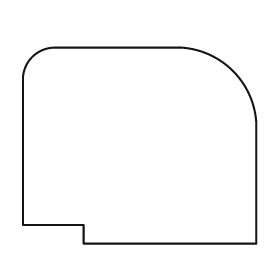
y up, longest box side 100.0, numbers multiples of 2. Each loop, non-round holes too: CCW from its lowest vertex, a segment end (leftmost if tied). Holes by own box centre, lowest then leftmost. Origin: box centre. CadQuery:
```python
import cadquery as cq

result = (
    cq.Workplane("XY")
    .moveTo(-24.0, -42.0)
    .lineTo(50.0, -42.0)
    .lineTo(50.0, 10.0)
    .threePointArc((40.0, 32.0), (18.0, 42.0))
    .lineTo(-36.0, 42.0)
    .threePointArc((-46.0, 38.0), (-50.0, 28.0))
    .lineTo(-50.0, -34.0)
    .lineTo(-24.0, -34.0)
    .close()
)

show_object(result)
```